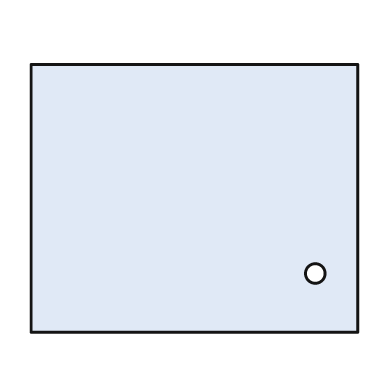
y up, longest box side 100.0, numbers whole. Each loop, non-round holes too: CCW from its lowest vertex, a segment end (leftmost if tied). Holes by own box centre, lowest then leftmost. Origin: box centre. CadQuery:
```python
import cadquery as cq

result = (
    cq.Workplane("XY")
    .moveTo(-50.0, -41.0)
    .lineTo(50.0, -41.0)
    .lineTo(50.0, 41.0)
    .lineTo(-50.0, 41.0)
    .close()
    .moveTo(37.0, -23.0)
    .circle(3.0)
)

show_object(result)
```